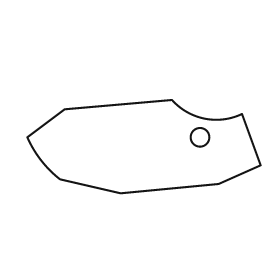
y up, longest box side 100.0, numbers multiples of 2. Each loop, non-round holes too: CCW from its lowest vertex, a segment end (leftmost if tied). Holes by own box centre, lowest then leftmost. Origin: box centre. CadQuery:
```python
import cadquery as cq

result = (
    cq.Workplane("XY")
    .moveTo(-10.0, -20.0)
    .lineTo(32.0, -16.0)
    .lineTo(50.0, -8.0)
    .lineTo(42.0, 14.0)
    .threePointArc((26.0, 12.0), (12.0, 20.0))
    .lineTo(-34.0, 16.0)
    .lineTo(-50.0, 4.0)
    .threePointArc((-44.0, -6.0), (-36.0, -14.0))
    .close()
    .moveTo(24.0, 4.0)
    .circle(4.0)
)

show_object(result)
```